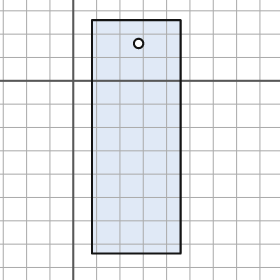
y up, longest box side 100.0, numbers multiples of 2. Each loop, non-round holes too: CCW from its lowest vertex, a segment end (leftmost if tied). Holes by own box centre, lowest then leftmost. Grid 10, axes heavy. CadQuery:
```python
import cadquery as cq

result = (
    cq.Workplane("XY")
    .moveTo(8.0, -74.0)
    .lineTo(46.0, -74.0)
    .lineTo(46.0, 26.0)
    .lineTo(8.0, 26.0)
    .close()
    .moveTo(28.0, 16.0)
    .circle(2.0)
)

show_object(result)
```